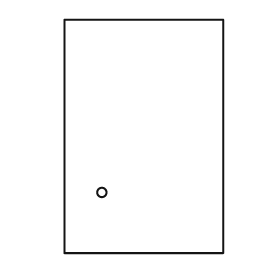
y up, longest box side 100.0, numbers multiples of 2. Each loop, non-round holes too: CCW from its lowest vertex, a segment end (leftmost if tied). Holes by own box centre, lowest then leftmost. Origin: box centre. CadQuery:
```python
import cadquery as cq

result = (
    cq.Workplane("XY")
    .moveTo(-34.0, -50.0)
    .lineTo(34.0, -50.0)
    .lineTo(34.0, 50.0)
    .lineTo(-34.0, 50.0)
    .close()
    .moveTo(-18.0, -24.0)
    .circle(2.0)
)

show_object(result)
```